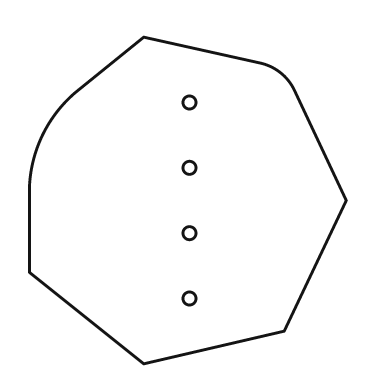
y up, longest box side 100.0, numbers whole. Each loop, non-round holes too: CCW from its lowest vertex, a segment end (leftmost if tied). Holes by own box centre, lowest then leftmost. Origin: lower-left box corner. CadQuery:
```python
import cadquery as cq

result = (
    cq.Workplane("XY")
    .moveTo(35.0, 0.0)
    .lineTo(78.0, 10.0)
    .lineTo(97.0, 50.0)
    .lineTo(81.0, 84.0)
    .threePointArc((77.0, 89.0), (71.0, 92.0))
    .lineTo(35.0, 100.0)
    .lineTo(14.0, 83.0)
    .threePointArc((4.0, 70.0), (0.0, 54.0))
    .lineTo(0.0, 28.0)
    .close()
    .moveTo(49.0, 20.0)
    .circle(2.0)
    .moveTo(49.0, 40.0)
    .circle(2.0)
    .moveTo(49.0, 60.0)
    .circle(2.0)
    .moveTo(49.0, 80.0)
    .circle(2.0)
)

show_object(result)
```